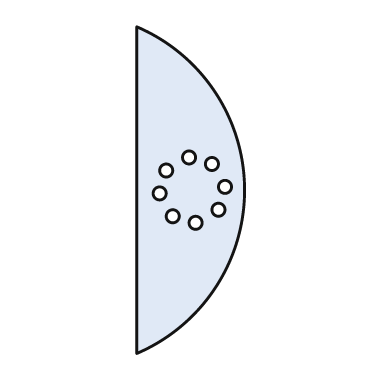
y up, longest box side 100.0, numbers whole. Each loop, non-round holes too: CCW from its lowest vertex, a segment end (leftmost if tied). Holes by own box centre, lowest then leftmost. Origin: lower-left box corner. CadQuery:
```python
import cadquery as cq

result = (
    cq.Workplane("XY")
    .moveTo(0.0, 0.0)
    .threePointArc((33.0, 50.0), (0.0, 100.0))
    .close()
    .moveTo(18.0, 40.0)
    .circle(2.0)
    .moveTo(11.0, 42.0)
    .circle(2.0)
    .moveTo(25.0, 44.0)
    .circle(2.0)
    .moveTo(7.0, 49.0)
    .circle(2.0)
    .moveTo(27.0, 51.0)
    .circle(2.0)
    .moveTo(9.0, 56.0)
    .circle(2.0)
    .moveTo(23.0, 58.0)
    .circle(2.0)
    .moveTo(16.0, 60.0)
    .circle(2.0)
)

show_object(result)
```